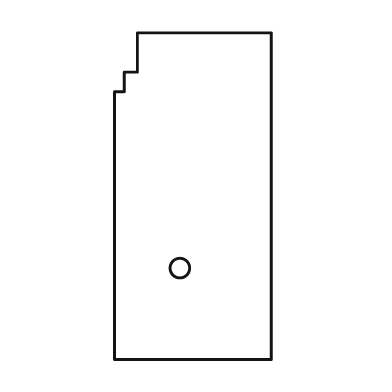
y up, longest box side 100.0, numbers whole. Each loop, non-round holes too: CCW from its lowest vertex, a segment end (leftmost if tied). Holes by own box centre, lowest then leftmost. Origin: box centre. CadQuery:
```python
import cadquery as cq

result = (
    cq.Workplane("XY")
    .moveTo(-24.0, -50.0)
    .lineTo(24.0, -50.0)
    .lineTo(24.0, 50.0)
    .lineTo(-17.0, 50.0)
    .lineTo(-17.0, 38.0)
    .lineTo(-21.0, 38.0)
    .lineTo(-21.0, 32.0)
    .lineTo(-24.0, 32.0)
    .close()
    .moveTo(-4.0, -22.0)
    .circle(3.0)
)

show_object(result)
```